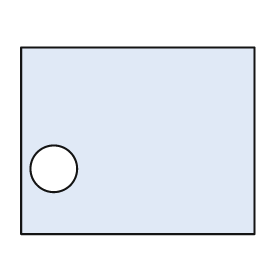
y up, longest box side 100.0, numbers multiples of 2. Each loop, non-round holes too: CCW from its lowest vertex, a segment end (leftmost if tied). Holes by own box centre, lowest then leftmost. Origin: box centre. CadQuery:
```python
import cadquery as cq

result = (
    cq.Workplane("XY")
    .moveTo(-50.0, -40.0)
    .lineTo(50.0, -40.0)
    .lineTo(50.0, 40.0)
    .lineTo(-50.0, 40.0)
    .close()
    .moveTo(-36.0, -12.0)
    .circle(10.0)
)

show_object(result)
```